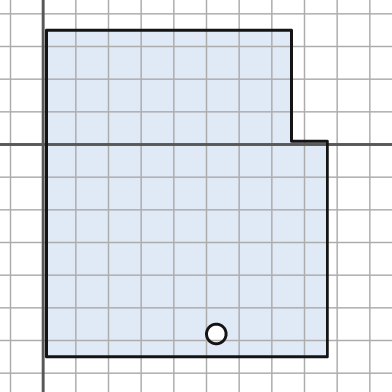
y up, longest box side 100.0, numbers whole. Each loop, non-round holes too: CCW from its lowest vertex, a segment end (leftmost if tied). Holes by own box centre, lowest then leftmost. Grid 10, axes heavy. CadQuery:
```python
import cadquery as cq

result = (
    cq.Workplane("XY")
    .moveTo(1.0, -65.0)
    .lineTo(87.0, -65.0)
    .lineTo(87.0, 1.0)
    .lineTo(76.0, 1.0)
    .lineTo(76.0, 35.0)
    .lineTo(1.0, 35.0)
    .close()
    .moveTo(53.0, -58.0)
    .circle(3.0)
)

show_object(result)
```